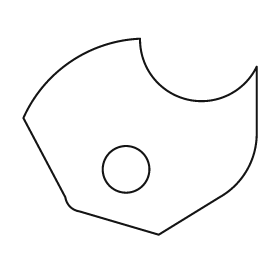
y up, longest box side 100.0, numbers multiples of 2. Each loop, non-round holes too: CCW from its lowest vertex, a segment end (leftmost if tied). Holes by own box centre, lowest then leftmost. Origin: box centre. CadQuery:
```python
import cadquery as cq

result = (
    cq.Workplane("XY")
    .moveTo(8.0, -42.0)
    .lineTo(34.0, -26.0)
    .threePointArc((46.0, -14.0), (50.0, 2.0))
    .lineTo(50.0, 30.0)
    .threePointArc((20.0, 16.0), (0.0, 42.0))
    .threePointArc((-30.0, 32.0), (-50.0, 8.0))
    .lineTo(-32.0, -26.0)
    .threePointArc((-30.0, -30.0), (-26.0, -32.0))
    .close()
    .moveTo(-6.0, -14.0)
    .circle(10.0)
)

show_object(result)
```